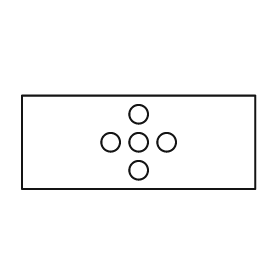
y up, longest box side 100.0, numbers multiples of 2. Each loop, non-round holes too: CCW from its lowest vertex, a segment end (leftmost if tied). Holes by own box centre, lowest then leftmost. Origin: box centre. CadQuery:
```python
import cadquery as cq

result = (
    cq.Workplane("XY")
    .moveTo(-50.0, -20.0)
    .lineTo(50.0, -20.0)
    .lineTo(50.0, 20.0)
    .lineTo(-50.0, 20.0)
    .close()
    .moveTo(0.0, -12.0)
    .circle(4.0)
    .moveTo(-12.0, 0.0)
    .circle(4.0)
    .moveTo(0.0, 0.0)
    .circle(4.0)
    .moveTo(12.0, 0.0)
    .circle(4.0)
    .moveTo(0.0, 12.0)
    .circle(4.0)
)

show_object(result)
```